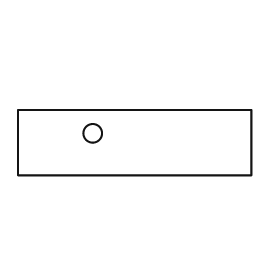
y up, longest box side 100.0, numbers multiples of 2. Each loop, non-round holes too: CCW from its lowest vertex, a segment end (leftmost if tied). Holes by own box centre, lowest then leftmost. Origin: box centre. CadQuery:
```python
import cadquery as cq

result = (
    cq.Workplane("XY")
    .moveTo(-50.0, -14.0)
    .lineTo(50.0, -14.0)
    .lineTo(50.0, 14.0)
    .lineTo(-50.0, 14.0)
    .close()
    .moveTo(-18.0, 4.0)
    .circle(4.0)
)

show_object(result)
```